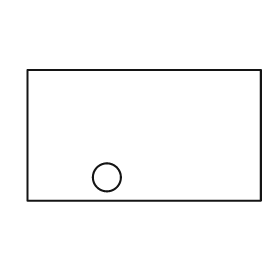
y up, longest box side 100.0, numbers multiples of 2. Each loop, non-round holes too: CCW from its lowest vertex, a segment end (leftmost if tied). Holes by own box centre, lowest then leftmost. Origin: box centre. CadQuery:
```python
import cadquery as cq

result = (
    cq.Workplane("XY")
    .moveTo(-50.0, -28.0)
    .lineTo(50.0, -28.0)
    .lineTo(50.0, 28.0)
    .lineTo(-50.0, 28.0)
    .close()
    .moveTo(-16.0, -18.0)
    .circle(6.0)
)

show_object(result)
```